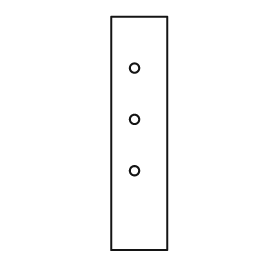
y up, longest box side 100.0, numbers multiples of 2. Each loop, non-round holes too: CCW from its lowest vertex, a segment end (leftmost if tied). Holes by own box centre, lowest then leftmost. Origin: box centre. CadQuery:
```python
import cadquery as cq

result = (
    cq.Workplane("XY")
    .moveTo(-12.0, -50.0)
    .lineTo(12.0, -50.0)
    .lineTo(12.0, 50.0)
    .lineTo(-12.0, 50.0)
    .close()
    .moveTo(-2.0, -16.0)
    .circle(2.0)
    .moveTo(-2.0, 6.0)
    .circle(2.0)
    .moveTo(-2.0, 28.0)
    .circle(2.0)
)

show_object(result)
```